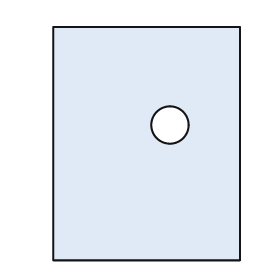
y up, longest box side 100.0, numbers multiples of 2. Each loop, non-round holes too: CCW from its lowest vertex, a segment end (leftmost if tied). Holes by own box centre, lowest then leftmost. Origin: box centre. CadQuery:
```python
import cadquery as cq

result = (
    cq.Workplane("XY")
    .moveTo(-40.0, -50.0)
    .lineTo(40.0, -50.0)
    .lineTo(40.0, 50.0)
    .lineTo(-40.0, 50.0)
    .close()
    .moveTo(10.0, 8.0)
    .circle(8.0)
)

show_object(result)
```